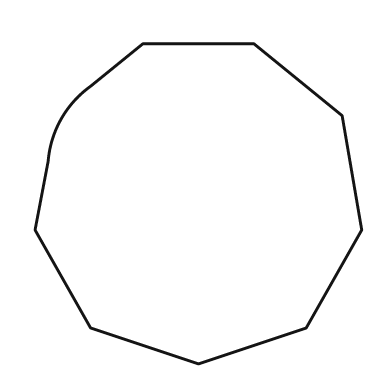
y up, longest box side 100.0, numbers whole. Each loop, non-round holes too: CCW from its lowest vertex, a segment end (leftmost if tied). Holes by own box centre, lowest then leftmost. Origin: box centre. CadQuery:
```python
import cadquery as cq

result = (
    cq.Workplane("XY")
    .moveTo(0.0, -49.0)
    .lineTo(33.0, -38.0)
    .lineTo(50.0, -8.0)
    .lineTo(44.0, 27.0)
    .lineTo(17.0, 49.0)
    .lineTo(-17.0, 49.0)
    .lineTo(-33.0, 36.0)
    .threePointArc((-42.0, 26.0), (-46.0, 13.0))
    .lineTo(-50.0, -8.0)
    .lineTo(-33.0, -38.0)
    .close()
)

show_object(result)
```